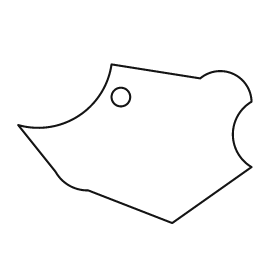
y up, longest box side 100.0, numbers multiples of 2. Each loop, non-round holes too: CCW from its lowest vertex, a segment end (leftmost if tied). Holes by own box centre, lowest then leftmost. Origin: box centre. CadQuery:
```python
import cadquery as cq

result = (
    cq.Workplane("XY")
    .moveTo(16.0, -34.0)
    .lineTo(50.0, -10.0)
    .threePointArc((42.0, 4.0), (50.0, 18.0))
    .threePointArc((42.0, 30.0), (28.0, 28.0))
    .lineTo(-10.0, 34.0)
    .threePointArc((-24.0, 12.0), (-50.0, 8.0))
    .lineTo(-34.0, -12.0)
    .threePointArc((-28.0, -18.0), (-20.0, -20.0))
    .close()
    .moveTo(-6.0, 20.0)
    .circle(4.0)
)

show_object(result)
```